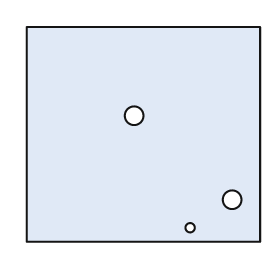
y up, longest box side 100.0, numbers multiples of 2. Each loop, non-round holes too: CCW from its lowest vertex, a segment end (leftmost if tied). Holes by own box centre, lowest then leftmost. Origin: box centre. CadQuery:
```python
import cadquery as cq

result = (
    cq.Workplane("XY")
    .moveTo(-50.0, -46.0)
    .lineTo(50.0, -46.0)
    .lineTo(50.0, 46.0)
    .lineTo(-50.0, 46.0)
    .close()
    .moveTo(20.0, -40.0)
    .circle(2.0)
    .moveTo(38.0, -28.0)
    .circle(4.0)
    .moveTo(-4.0, 8.0)
    .circle(4.0)
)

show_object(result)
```